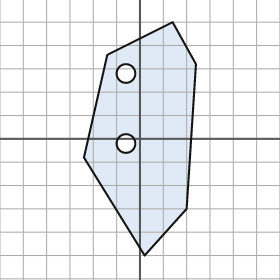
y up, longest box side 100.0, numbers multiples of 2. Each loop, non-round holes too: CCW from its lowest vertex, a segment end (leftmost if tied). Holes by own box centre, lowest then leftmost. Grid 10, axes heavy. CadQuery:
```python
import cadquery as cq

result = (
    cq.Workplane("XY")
    .moveTo(2.0, -50.0)
    .lineTo(20.0, -30.0)
    .lineTo(24.0, 32.0)
    .lineTo(14.0, 50.0)
    .lineTo(-14.0, 36.0)
    .lineTo(-24.0, -8.0)
    .close()
    .moveTo(-6.0, -2.0)
    .circle(4.0)
    .moveTo(-6.0, 28.0)
    .circle(4.0)
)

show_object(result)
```